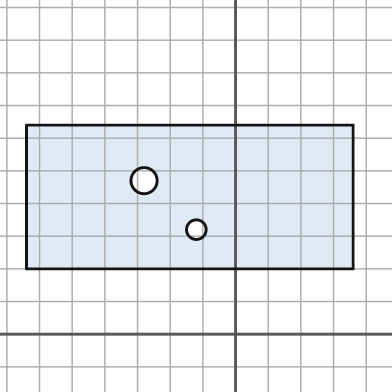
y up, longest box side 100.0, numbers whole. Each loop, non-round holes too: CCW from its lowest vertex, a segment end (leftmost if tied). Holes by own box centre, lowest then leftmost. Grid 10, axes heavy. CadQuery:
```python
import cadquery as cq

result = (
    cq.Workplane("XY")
    .moveTo(-64.0, 20.0)
    .lineTo(36.0, 20.0)
    .lineTo(36.0, 64.0)
    .lineTo(-64.0, 64.0)
    .close()
    .moveTo(-12.0, 32.0)
    .circle(3.0)
    .moveTo(-28.0, 47.0)
    .circle(4.0)
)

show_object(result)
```